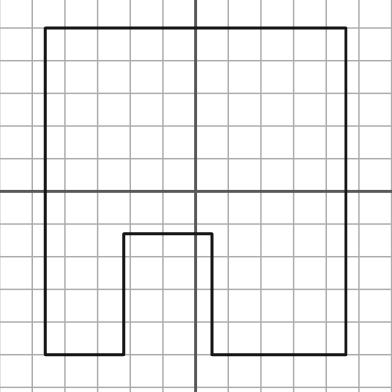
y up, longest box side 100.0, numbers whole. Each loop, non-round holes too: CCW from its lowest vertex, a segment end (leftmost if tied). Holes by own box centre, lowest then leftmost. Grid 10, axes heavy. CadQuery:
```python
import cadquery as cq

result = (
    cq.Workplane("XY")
    .moveTo(-46.0, -50.0)
    .lineTo(-22.0, -50.0)
    .lineTo(-22.0, -13.0)
    .lineTo(5.0, -13.0)
    .lineTo(5.0, -50.0)
    .lineTo(46.0, -50.0)
    .lineTo(46.0, 50.0)
    .lineTo(-46.0, 50.0)
    .close()
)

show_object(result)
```